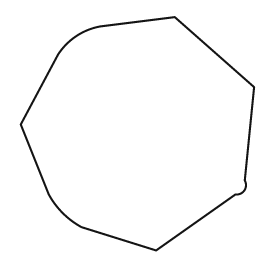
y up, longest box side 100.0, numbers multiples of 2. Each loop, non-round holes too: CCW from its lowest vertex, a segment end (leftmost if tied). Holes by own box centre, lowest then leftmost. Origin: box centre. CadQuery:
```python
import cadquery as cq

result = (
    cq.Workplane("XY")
    .moveTo(8.0, -50.0)
    .lineTo(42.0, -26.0)
    .threePointArc((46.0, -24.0), (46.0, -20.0))
    .lineTo(50.0, 20.0)
    .lineTo(16.0, 50.0)
    .lineTo(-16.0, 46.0)
    .threePointArc((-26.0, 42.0), (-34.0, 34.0))
    .lineTo(-50.0, 4.0)
    .lineTo(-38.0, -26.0)
    .threePointArc((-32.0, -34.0), (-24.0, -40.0))
    .close()
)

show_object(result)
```